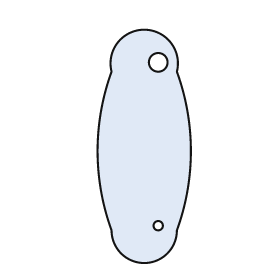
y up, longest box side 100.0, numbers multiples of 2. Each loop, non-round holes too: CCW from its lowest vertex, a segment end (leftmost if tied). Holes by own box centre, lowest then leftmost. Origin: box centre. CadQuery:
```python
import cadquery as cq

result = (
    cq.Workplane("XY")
    .moveTo(-14.0, -36.0)
    .threePointArc((0.0, -50.0), (14.0, -36.0))
    .threePointArc((20.0, -2.0), (14.0, 32.0))
    .threePointArc((0.0, 50.0), (-14.0, 32.0))
    .threePointArc((-20.0, -2.0), (-14.0, -36.0))
    .close()
    .moveTo(6.0, -34.0)
    .circle(2.0)
    .moveTo(6.0, 36.0)
    .circle(4.0)
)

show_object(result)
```